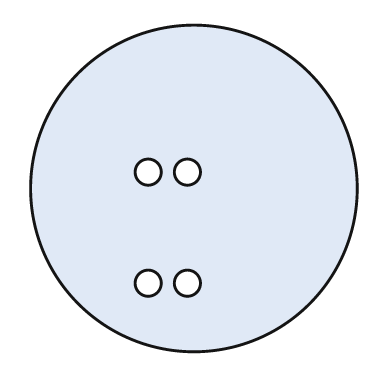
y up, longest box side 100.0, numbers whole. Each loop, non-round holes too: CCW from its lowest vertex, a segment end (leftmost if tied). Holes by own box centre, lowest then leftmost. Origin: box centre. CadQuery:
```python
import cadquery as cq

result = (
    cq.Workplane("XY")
    .moveTo(0.0, 0.0)
    .circle(50.0)
    .moveTo(-14.0, -29.0)
    .circle(4.0)
    .moveTo(-2.0, -29.0)
    .circle(4.0)
    .moveTo(-14.0, 5.0)
    .circle(4.0)
    .moveTo(-2.0, 5.0)
    .circle(4.0)
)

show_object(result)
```